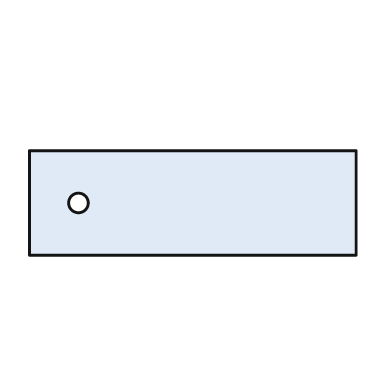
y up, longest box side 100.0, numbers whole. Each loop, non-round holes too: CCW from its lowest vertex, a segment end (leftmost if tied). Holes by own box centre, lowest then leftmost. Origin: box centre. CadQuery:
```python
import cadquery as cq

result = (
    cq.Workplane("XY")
    .moveTo(-50.0, -16.0)
    .lineTo(50.0, -16.0)
    .lineTo(50.0, 16.0)
    .lineTo(-50.0, 16.0)
    .close()
    .moveTo(-35.0, 0.0)
    .circle(3.0)
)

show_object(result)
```